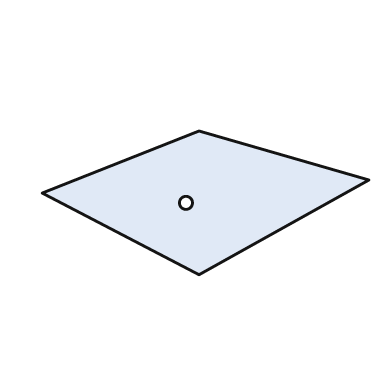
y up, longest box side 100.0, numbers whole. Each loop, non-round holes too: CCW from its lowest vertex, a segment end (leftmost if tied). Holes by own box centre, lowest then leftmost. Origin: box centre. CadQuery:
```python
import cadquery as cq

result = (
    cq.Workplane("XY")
    .moveTo(-2.0, -22.0)
    .lineTo(50.0, 7.0)
    .lineTo(-2.0, 22.0)
    .lineTo(-50.0, 3.0)
    .close()
    .moveTo(-6.0, 0.0)
    .circle(2.0)
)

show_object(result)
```